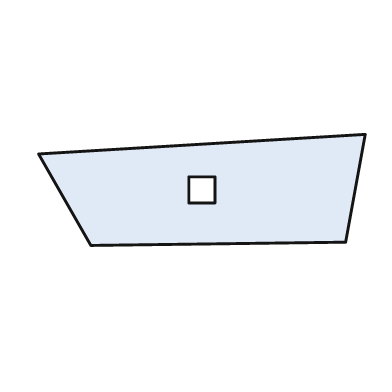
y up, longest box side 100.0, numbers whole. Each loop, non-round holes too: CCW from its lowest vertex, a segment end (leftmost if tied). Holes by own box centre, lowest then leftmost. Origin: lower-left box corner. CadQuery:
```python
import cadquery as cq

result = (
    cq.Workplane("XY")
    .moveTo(16.0, 0.0)
    .lineTo(94.0, 1.0)
    .lineTo(100.0, 34.0)
    .lineTo(0.0, 28.0)
    .close()
    .moveTo(46.0, 13.0)
    .lineTo(54.0, 13.0)
    .lineTo(54.0, 21.0)
    .lineTo(46.0, 21.0)
    .close()
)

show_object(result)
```